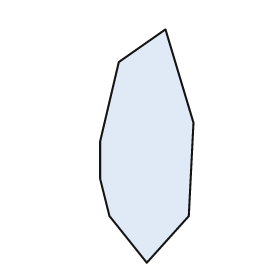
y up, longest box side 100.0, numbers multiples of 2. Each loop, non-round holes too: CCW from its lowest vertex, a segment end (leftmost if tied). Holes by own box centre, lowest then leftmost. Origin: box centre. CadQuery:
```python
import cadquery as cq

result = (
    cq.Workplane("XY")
    .moveTo(0.0, -50.0)
    .lineTo(18.0, -30.0)
    .lineTo(20.0, 10.0)
    .lineTo(8.0, 50.0)
    .lineTo(-12.0, 36.0)
    .lineTo(-20.0, 2.0)
    .lineTo(-20.0, -14.0)
    .lineTo(-16.0, -30.0)
    .close()
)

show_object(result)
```